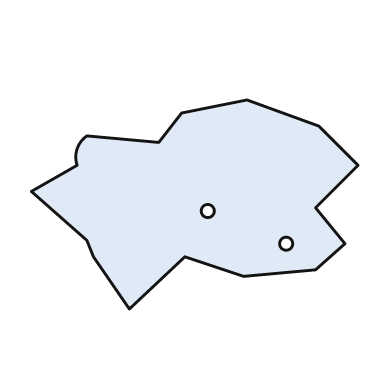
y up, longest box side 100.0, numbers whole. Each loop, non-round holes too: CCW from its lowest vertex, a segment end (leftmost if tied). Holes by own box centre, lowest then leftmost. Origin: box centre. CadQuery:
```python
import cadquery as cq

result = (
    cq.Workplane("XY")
    .moveTo(-20.0, -32.0)
    .lineTo(-3.0, -16.0)
    .lineTo(15.0, -22.0)
    .lineTo(37.0, -20.0)
    .lineTo(46.0, -12.0)
    .lineTo(37.0, -1.0)
    .lineTo(50.0, 12.0)
    .lineTo(38.0, 24.0)
    .lineTo(16.0, 32.0)
    .lineTo(-4.0, 28.0)
    .lineTo(-11.0, 19.0)
    .lineTo(-33.0, 21.0)
    .threePointArc((-36.0, 17.0), (-36.0, 12.0))
    .lineTo(-50.0, 4.0)
    .lineTo(-33.0, -11.0)
    .lineTo(-31.0, -16.0)
    .close()
    .moveTo(28.0, -12.0)
    .circle(2.0)
    .moveTo(4.0, -2.0)
    .circle(2.0)
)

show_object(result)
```